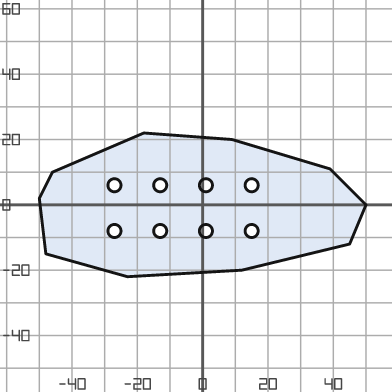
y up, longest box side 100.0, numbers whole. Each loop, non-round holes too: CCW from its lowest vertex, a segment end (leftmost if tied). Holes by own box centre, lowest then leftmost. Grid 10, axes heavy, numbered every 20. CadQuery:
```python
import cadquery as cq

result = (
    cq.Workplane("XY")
    .moveTo(-23.0, -22.0)
    .lineTo(12.0, -20.0)
    .lineTo(45.0, -12.0)
    .lineTo(50.0, 0.0)
    .lineTo(39.0, 11.0)
    .lineTo(9.0, 20.0)
    .lineTo(-18.0, 22.0)
    .lineTo(-46.0, 10.0)
    .lineTo(-50.0, 2.0)
    .lineTo(-48.0, -15.0)
    .close()
    .moveTo(-27.0, -8.0)
    .circle(2.0)
    .moveTo(-13.0, -8.0)
    .circle(2.0)
    .moveTo(1.0, -8.0)
    .circle(2.0)
    .moveTo(15.0, -8.0)
    .circle(2.0)
    .moveTo(-27.0, 6.0)
    .circle(2.0)
    .moveTo(-13.0, 6.0)
    .circle(2.0)
    .moveTo(1.0, 6.0)
    .circle(2.0)
    .moveTo(15.0, 6.0)
    .circle(2.0)
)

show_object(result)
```